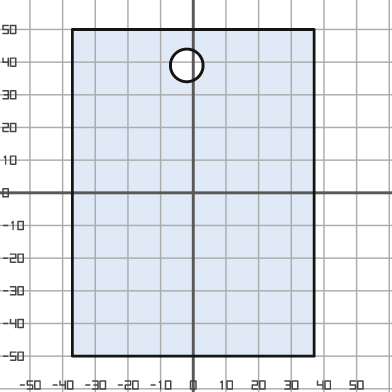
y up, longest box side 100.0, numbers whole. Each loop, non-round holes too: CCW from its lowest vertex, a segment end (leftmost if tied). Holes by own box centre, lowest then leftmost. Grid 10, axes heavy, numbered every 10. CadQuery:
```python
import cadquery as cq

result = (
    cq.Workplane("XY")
    .moveTo(-37.0, -50.0)
    .lineTo(37.0, -50.0)
    .lineTo(37.0, 50.0)
    .lineTo(-37.0, 50.0)
    .close()
    .moveTo(-2.0, 39.0)
    .circle(5.0)
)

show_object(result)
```